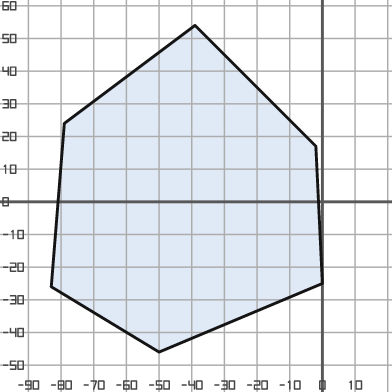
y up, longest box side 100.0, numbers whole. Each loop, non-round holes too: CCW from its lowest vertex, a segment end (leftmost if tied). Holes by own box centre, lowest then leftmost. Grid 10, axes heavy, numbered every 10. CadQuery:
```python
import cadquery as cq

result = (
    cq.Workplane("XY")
    .moveTo(-50.0, -46.0)
    .lineTo(0.0, -25.0)
    .lineTo(-2.0, 17.0)
    .lineTo(-39.0, 54.0)
    .lineTo(-79.0, 24.0)
    .lineTo(-83.0, -26.0)
    .close()
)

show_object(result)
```